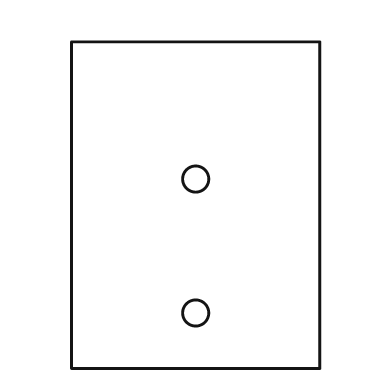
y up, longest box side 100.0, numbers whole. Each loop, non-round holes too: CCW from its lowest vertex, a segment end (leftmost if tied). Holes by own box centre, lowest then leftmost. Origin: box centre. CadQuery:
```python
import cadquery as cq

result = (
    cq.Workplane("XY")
    .moveTo(-38.0, -50.0)
    .lineTo(38.0, -50.0)
    .lineTo(38.0, 50.0)
    .lineTo(-38.0, 50.0)
    .close()
    .moveTo(0.0, -33.0)
    .circle(4.0)
    .moveTo(0.0, 8.0)
    .circle(4.0)
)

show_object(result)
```